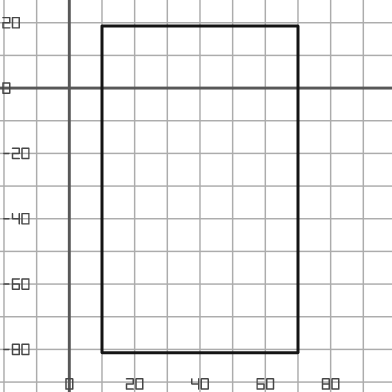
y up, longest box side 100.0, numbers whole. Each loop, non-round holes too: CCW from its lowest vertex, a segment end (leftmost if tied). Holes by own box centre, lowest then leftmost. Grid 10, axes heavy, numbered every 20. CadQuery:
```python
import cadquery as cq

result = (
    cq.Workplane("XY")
    .moveTo(10.0, -81.0)
    .lineTo(70.0, -81.0)
    .lineTo(70.0, 19.0)
    .lineTo(10.0, 19.0)
    .close()
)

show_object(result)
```